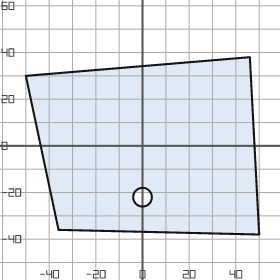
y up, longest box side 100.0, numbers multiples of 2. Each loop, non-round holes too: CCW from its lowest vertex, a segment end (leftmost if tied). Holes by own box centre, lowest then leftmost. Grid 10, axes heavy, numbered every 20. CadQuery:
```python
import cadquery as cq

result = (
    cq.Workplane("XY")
    .moveTo(50.0, -38.0)
    .lineTo(46.0, 38.0)
    .lineTo(-50.0, 30.0)
    .lineTo(-36.0, -36.0)
    .close()
    .moveTo(0.0, -22.0)
    .circle(4.0)
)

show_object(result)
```